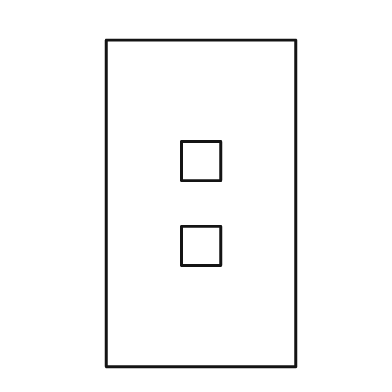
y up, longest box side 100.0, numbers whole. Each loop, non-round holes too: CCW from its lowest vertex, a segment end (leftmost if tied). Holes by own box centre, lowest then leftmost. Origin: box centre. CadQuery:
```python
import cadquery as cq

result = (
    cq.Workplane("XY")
    .moveTo(-29.0, -50.0)
    .lineTo(29.0, -50.0)
    .lineTo(29.0, 50.0)
    .lineTo(-29.0, 50.0)
    .close()
    .moveTo(-6.0, -19.0)
    .lineTo(6.0, -19.0)
    .lineTo(6.0, -7.0)
    .lineTo(-6.0, -7.0)
    .close()
    .moveTo(-6.0, 7.0)
    .lineTo(6.0, 7.0)
    .lineTo(6.0, 19.0)
    .lineTo(-6.0, 19.0)
    .close()
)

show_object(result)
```